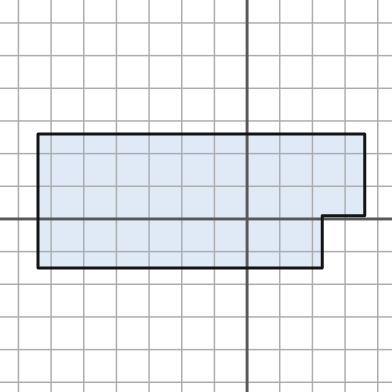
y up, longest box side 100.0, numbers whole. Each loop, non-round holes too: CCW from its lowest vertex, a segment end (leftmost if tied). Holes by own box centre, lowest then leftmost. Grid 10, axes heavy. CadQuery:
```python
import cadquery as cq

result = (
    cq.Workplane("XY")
    .moveTo(-64.0, -15.0)
    .lineTo(23.0, -15.0)
    .lineTo(23.0, 1.0)
    .lineTo(36.0, 1.0)
    .lineTo(36.0, 26.0)
    .lineTo(-64.0, 26.0)
    .close()
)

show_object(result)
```